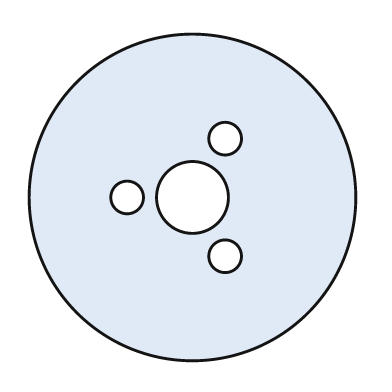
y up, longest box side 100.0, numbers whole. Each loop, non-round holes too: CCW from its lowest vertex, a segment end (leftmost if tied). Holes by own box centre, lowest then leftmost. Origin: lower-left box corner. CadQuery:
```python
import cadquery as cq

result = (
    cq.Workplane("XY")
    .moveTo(50.0, 50.0)
    .circle(50.0)
    .moveTo(60.0, 32.0)
    .circle(5.0)
    .moveTo(30.0, 50.0)
    .circle(5.0)
    .moveTo(50.0, 50.0)
    .circle(11.0)
    .moveTo(60.0, 68.0)
    .circle(5.0)
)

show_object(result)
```